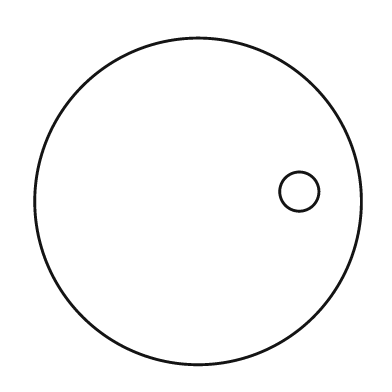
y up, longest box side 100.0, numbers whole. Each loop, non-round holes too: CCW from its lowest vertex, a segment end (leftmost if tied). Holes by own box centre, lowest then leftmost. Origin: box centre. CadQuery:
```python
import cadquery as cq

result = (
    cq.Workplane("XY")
    .moveTo(0.0, 0.0)
    .circle(50.0)
    .moveTo(31.0, 3.0)
    .circle(6.0)
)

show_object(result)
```